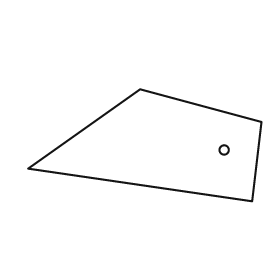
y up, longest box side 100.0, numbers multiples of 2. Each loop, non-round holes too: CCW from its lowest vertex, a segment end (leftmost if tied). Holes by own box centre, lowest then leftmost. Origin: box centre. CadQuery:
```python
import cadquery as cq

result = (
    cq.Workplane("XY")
    .moveTo(46.0, -24.0)
    .lineTo(50.0, 10.0)
    .lineTo(-2.0, 24.0)
    .lineTo(-50.0, -10.0)
    .close()
    .moveTo(34.0, -2.0)
    .circle(2.0)
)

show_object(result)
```